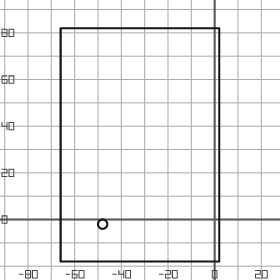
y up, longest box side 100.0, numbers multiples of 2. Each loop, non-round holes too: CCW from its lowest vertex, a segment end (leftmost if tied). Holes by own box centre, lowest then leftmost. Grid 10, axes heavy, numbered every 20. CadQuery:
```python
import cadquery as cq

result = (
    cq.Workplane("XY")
    .moveTo(-66.0, -18.0)
    .lineTo(2.0, -18.0)
    .lineTo(2.0, 82.0)
    .lineTo(-66.0, 82.0)
    .close()
    .moveTo(-48.0, -2.0)
    .circle(2.0)
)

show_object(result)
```